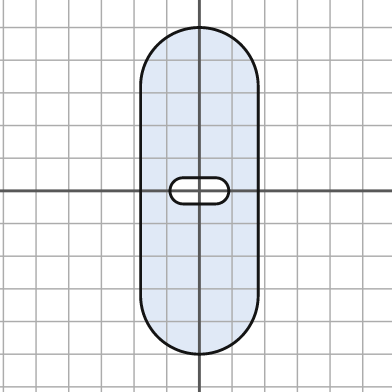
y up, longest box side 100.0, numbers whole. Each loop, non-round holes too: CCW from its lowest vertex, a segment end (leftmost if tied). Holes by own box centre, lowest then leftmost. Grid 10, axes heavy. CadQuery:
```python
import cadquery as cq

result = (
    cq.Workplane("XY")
    .moveTo(-18.0, -32.0)
    .threePointArc((0.0, -50.0), (18.0, -32.0))
    .lineTo(18.0, 32.0)
    .threePointArc((0.0, 50.0), (-18.0, 32.0))
    .close()
    .moveTo(-5.0, -4.0)
    .lineTo(5.0, -4.0)
    .threePointArc((9.0, 0.0), (5.0, 4.0))
    .lineTo(-5.0, 4.0)
    .threePointArc((-9.0, 0.0), (-5.0, -4.0))
    .close()
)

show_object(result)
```